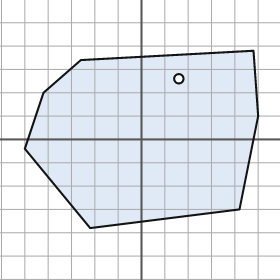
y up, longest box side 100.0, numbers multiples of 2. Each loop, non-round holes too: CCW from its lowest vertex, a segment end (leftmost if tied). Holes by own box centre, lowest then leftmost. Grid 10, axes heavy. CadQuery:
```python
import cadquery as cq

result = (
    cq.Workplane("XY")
    .moveTo(-22.0, -38.0)
    .lineTo(42.0, -30.0)
    .lineTo(50.0, 10.0)
    .lineTo(48.0, 38.0)
    .lineTo(-26.0, 34.0)
    .lineTo(-42.0, 20.0)
    .lineTo(-50.0, -4.0)
    .close()
    .moveTo(16.0, 26.0)
    .circle(2.0)
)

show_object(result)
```